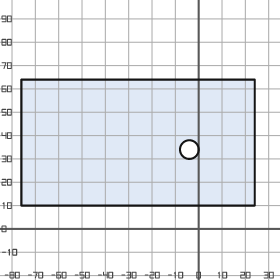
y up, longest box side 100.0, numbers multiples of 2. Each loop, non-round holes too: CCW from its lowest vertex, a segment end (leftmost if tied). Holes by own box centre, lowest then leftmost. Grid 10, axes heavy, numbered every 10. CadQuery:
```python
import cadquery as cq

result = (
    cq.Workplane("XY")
    .moveTo(-76.0, 10.0)
    .lineTo(24.0, 10.0)
    .lineTo(24.0, 64.0)
    .lineTo(-76.0, 64.0)
    .close()
    .moveTo(-4.0, 34.0)
    .circle(4.0)
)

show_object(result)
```